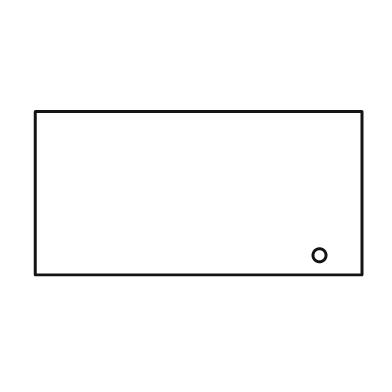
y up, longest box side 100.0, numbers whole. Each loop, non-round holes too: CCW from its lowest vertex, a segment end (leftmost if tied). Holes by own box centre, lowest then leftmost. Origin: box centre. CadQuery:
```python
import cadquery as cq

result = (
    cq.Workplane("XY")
    .moveTo(-50.0, -25.0)
    .lineTo(50.0, -25.0)
    .lineTo(50.0, 25.0)
    .lineTo(-50.0, 25.0)
    .close()
    .moveTo(37.0, -19.0)
    .circle(2.0)
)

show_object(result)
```